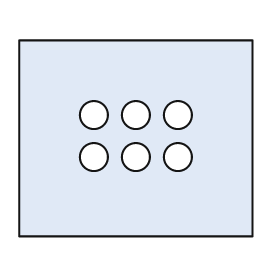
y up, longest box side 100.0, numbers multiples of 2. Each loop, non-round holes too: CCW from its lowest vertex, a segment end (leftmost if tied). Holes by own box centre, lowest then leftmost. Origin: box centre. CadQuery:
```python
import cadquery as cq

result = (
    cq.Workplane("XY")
    .moveTo(-50.0, -42.0)
    .lineTo(50.0, -42.0)
    .lineTo(50.0, 42.0)
    .lineTo(-50.0, 42.0)
    .close()
    .moveTo(-18.0, -8.0)
    .circle(6.0)
    .moveTo(0.0, -8.0)
    .circle(6.0)
    .moveTo(18.0, -8.0)
    .circle(6.0)
    .moveTo(-18.0, 10.0)
    .circle(6.0)
    .moveTo(0.0, 10.0)
    .circle(6.0)
    .moveTo(18.0, 10.0)
    .circle(6.0)
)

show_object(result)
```